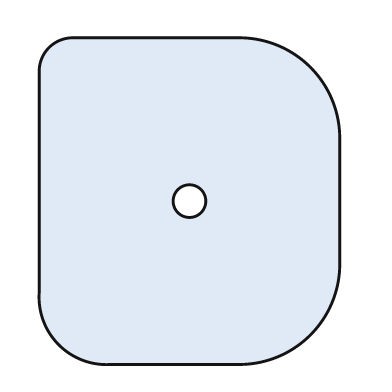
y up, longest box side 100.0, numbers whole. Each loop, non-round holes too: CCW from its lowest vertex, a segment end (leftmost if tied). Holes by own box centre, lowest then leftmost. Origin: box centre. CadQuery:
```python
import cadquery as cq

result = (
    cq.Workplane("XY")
    .moveTo(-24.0, -50.0)
    .lineTo(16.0, -50.0)
    .threePointArc((37.0, -41.0), (46.0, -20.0))
    .lineTo(46.0, 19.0)
    .threePointArc((37.0, 41.0), (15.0, 50.0))
    .lineTo(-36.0, 50.0)
    .threePointArc((-43.0, 47.0), (-46.0, 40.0))
    .lineTo(-46.0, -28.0)
    .threePointArc((-40.0, -44.0), (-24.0, -50.0))
    .close()
    .moveTo(0.0, 0.0)
    .circle(5.0)
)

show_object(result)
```